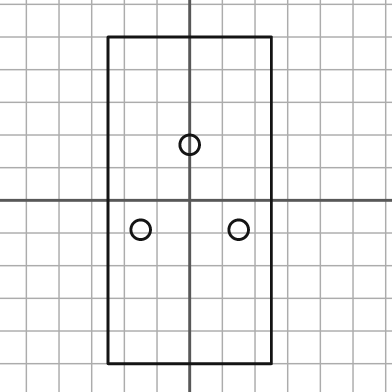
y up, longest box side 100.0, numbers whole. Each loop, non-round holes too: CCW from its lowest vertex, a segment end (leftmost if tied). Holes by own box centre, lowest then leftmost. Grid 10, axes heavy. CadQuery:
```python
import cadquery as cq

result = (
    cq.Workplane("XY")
    .moveTo(-25.0, -50.0)
    .lineTo(25.0, -50.0)
    .lineTo(25.0, 50.0)
    .lineTo(-25.0, 50.0)
    .close()
    .moveTo(-15.0, -9.0)
    .circle(3.0)
    .moveTo(15.0, -9.0)
    .circle(3.0)
    .moveTo(0.0, 17.0)
    .circle(3.0)
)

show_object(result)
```